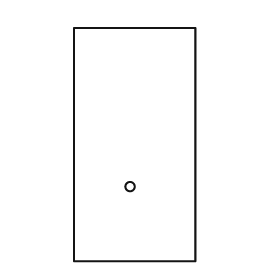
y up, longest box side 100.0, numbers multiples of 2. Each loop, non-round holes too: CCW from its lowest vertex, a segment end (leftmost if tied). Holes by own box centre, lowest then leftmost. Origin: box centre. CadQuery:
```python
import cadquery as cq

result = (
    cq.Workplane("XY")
    .moveTo(-26.0, -50.0)
    .lineTo(26.0, -50.0)
    .lineTo(26.0, 50.0)
    .lineTo(-26.0, 50.0)
    .close()
    .moveTo(-2.0, -18.0)
    .circle(2.0)
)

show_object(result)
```